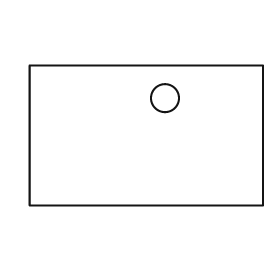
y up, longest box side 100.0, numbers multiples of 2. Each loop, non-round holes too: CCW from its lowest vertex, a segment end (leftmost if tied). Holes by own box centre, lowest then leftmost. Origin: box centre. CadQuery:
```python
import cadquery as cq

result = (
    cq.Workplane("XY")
    .moveTo(-50.0, -30.0)
    .lineTo(50.0, -30.0)
    .lineTo(50.0, 30.0)
    .lineTo(-50.0, 30.0)
    .close()
    .moveTo(8.0, 16.0)
    .circle(6.0)
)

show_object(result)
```